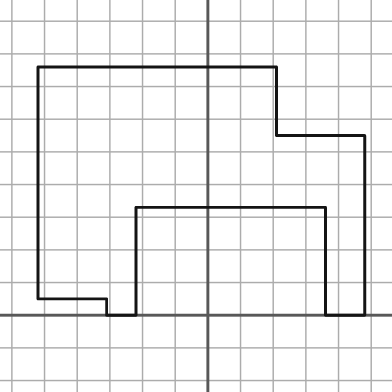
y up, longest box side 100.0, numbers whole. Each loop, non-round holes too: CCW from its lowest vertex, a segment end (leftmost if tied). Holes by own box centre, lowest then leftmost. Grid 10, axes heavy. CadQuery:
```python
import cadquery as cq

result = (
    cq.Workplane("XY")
    .moveTo(-31.0, 0.0)
    .lineTo(-22.0, 0.0)
    .lineTo(-22.0, 33.0)
    .lineTo(36.0, 33.0)
    .lineTo(36.0, 0.0)
    .lineTo(48.0, 0.0)
    .lineTo(48.0, 55.0)
    .lineTo(21.0, 55.0)
    .lineTo(21.0, 76.0)
    .lineTo(-52.0, 76.0)
    .lineTo(-52.0, 5.0)
    .lineTo(-31.0, 5.0)
    .close()
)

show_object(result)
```